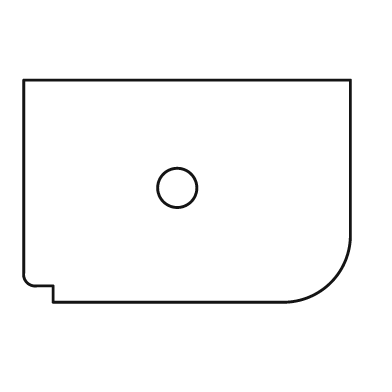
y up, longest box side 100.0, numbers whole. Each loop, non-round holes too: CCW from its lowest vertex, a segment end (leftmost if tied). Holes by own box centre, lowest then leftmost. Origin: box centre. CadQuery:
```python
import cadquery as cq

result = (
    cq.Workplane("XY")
    .moveTo(-41.0, -34.0)
    .lineTo(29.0, -34.0)
    .threePointArc((44.0, -28.0), (50.0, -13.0))
    .lineTo(50.0, 34.0)
    .lineTo(-50.0, 34.0)
    .lineTo(-50.0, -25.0)
    .threePointArc((-49.0, -28.0), (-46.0, -29.0))
    .lineTo(-41.0, -29.0)
    .close()
    .moveTo(-3.0, 1.0)
    .circle(6.0)
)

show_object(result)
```